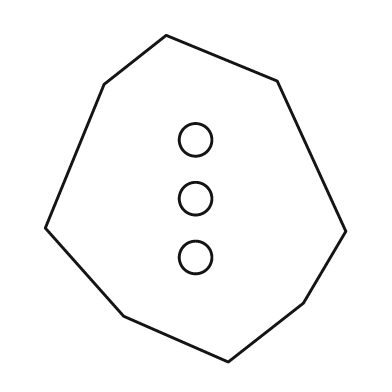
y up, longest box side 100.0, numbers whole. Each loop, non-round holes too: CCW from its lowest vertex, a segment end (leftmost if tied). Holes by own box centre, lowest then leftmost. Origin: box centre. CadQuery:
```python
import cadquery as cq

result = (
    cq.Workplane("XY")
    .moveTo(10.0, -50.0)
    .lineTo(33.0, -32.0)
    .lineTo(46.0, -10.0)
    .lineTo(25.0, 36.0)
    .lineTo(-9.0, 50.0)
    .lineTo(-28.0, 35.0)
    .lineTo(-46.0, -9.0)
    .lineTo(-22.0, -36.0)
    .close()
    .moveTo(0.0, -18.0)
    .circle(5.0)
    .moveTo(0.0, 0.0)
    .circle(5.0)
    .moveTo(0.0, 18.0)
    .circle(5.0)
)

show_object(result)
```